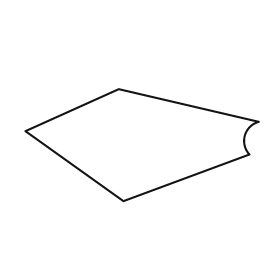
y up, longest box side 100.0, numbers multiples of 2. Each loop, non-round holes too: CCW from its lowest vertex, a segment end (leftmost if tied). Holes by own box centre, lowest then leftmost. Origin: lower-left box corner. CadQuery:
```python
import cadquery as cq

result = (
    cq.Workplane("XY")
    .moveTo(42.0, 0.0)
    .lineTo(96.0, 20.0)
    .threePointArc((94.0, 28.0), (100.0, 34.0))
    .lineTo(40.0, 48.0)
    .lineTo(0.0, 30.0)
    .close()
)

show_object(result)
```